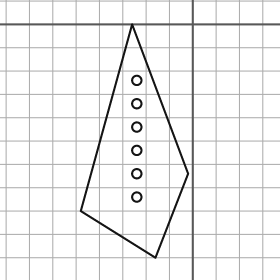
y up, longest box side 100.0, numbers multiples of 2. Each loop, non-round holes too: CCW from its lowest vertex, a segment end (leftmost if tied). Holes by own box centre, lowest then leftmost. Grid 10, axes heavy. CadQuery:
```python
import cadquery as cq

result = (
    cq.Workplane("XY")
    .moveTo(-16.0, -100.0)
    .lineTo(-2.0, -64.0)
    .lineTo(-26.0, 0.0)
    .lineTo(-48.0, -80.0)
    .close()
    .moveTo(-24.0, -74.0)
    .circle(2.0)
    .moveTo(-24.0, -64.0)
    .circle(2.0)
    .moveTo(-24.0, -54.0)
    .circle(2.0)
    .moveTo(-24.0, -44.0)
    .circle(2.0)
    .moveTo(-24.0, -34.0)
    .circle(2.0)
    .moveTo(-24.0, -24.0)
    .circle(2.0)
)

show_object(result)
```